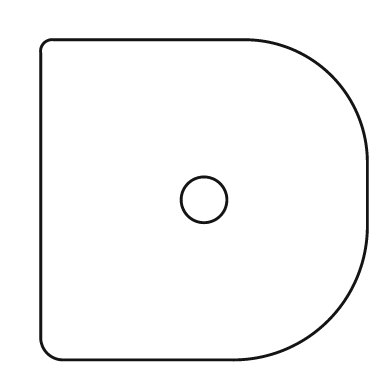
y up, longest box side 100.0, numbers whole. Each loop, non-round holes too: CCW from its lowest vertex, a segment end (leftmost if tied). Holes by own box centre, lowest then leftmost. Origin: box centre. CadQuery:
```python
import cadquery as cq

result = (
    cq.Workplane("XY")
    .moveTo(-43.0, -49.0)
    .lineTo(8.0, -49.0)
    .threePointArc((38.0, -37.0), (50.0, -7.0))
    .lineTo(50.0, 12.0)
    .threePointArc((39.0, 38.0), (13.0, 49.0))
    .lineTo(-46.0, 49.0)
    .threePointArc((-49.0, 48.0), (-50.0, 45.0))
    .lineTo(-50.0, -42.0)
    .threePointArc((-48.0, -47.0), (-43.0, -49.0))
    .close()
    .moveTo(0.0, 0.0)
    .circle(7.0)
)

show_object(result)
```